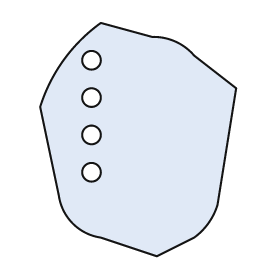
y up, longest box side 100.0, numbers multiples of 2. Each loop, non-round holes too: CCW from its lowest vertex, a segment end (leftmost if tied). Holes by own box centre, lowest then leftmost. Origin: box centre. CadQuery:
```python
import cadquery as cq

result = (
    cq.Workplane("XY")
    .moveTo(8.0, -50.0)
    .lineTo(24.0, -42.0)
    .threePointArc((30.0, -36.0), (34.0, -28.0))
    .lineTo(42.0, 22.0)
    .lineTo(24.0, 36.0)
    .threePointArc((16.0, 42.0), (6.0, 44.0))
    .lineTo(-16.0, 50.0)
    .threePointArc((-32.0, 34.0), (-42.0, 14.0))
    .lineTo(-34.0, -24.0)
    .threePointArc((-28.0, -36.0), (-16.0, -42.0))
    .close()
    .moveTo(-20.0, -14.0)
    .circle(4.0)
    .moveTo(-20.0, 2.0)
    .circle(4.0)
    .moveTo(-20.0, 18.0)
    .circle(4.0)
    .moveTo(-20.0, 34.0)
    .circle(4.0)
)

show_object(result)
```